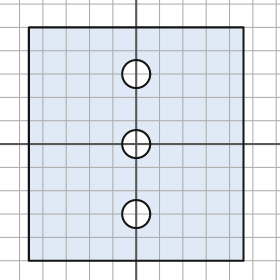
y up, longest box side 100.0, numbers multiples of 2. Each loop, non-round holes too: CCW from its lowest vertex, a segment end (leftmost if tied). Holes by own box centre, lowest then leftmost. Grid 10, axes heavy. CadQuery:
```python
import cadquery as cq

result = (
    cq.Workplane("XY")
    .moveTo(-46.0, -50.0)
    .lineTo(46.0, -50.0)
    .lineTo(46.0, 50.0)
    .lineTo(-46.0, 50.0)
    .close()
    .moveTo(0.0, -30.0)
    .circle(6.0)
    .moveTo(0.0, 0.0)
    .circle(6.0)
    .moveTo(0.0, 30.0)
    .circle(6.0)
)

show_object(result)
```